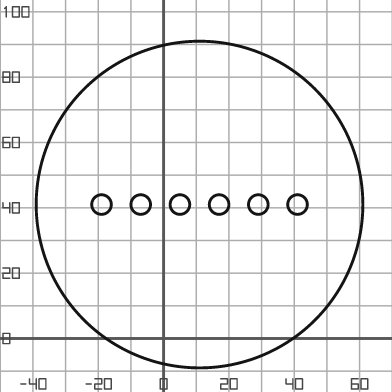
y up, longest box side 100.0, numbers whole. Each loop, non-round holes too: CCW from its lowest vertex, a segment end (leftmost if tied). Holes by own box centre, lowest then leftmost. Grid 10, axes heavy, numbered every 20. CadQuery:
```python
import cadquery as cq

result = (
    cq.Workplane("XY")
    .moveTo(11.0, 41.0)
    .circle(50.0)
    .moveTo(-19.0, 41.0)
    .circle(3.0)
    .moveTo(-7.0, 41.0)
    .circle(3.0)
    .moveTo(5.0, 41.0)
    .circle(3.0)
    .moveTo(17.0, 41.0)
    .circle(3.0)
    .moveTo(29.0, 41.0)
    .circle(3.0)
    .moveTo(41.0, 41.0)
    .circle(3.0)
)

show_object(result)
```